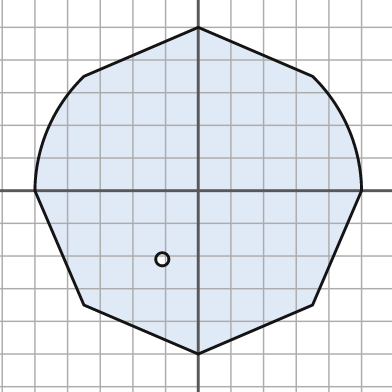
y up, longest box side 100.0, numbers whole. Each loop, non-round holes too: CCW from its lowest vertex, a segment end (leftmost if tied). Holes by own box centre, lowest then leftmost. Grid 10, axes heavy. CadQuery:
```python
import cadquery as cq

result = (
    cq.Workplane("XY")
    .moveTo(0.0, -50.0)
    .lineTo(35.0, -35.0)
    .lineTo(50.0, 0.0)
    .threePointArc((46.0, 19.0), (35.0, 35.0))
    .lineTo(0.0, 50.0)
    .lineTo(-35.0, 35.0)
    .threePointArc((-46.0, 19.0), (-50.0, 0.0))
    .lineTo(-35.0, -35.0)
    .close()
    .moveTo(-11.0, -21.0)
    .circle(2.0)
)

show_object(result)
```